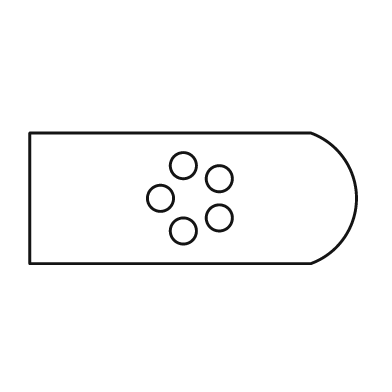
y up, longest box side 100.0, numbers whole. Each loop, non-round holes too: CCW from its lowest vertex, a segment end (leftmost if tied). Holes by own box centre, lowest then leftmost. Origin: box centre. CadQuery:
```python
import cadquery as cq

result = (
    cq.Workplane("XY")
    .moveTo(-50.0, -20.0)
    .lineTo(36.0, -20.0)
    .threePointArc((50.0, 0.0), (36.0, 20.0))
    .lineTo(-50.0, 20.0)
    .close()
    .moveTo(-3.0, -10.0)
    .circle(4.0)
    .moveTo(8.0, -6.0)
    .circle(4.0)
    .moveTo(-10.0, 0.0)
    .circle(4.0)
    .moveTo(8.0, 6.0)
    .circle(4.0)
    .moveTo(-3.0, 10.0)
    .circle(4.0)
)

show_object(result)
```